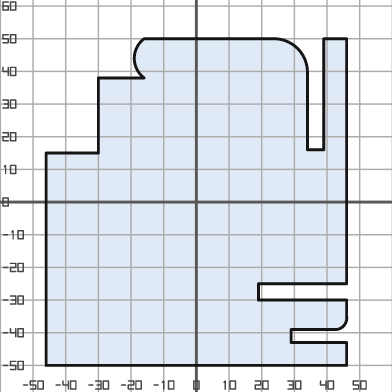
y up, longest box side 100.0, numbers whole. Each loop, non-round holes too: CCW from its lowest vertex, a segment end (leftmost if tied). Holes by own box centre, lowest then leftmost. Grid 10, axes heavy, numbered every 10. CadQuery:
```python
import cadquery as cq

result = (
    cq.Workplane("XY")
    .moveTo(-46.0, -50.0)
    .lineTo(46.0, -50.0)
    .lineTo(46.0, -43.0)
    .lineTo(29.0, -43.0)
    .lineTo(29.0, -39.0)
    .lineTo(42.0, -39.0)
    .threePointArc((45.0, -38.0), (46.0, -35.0))
    .lineTo(46.0, -30.0)
    .lineTo(19.0, -30.0)
    .lineTo(19.0, -25.0)
    .lineTo(46.0, -25.0)
    .lineTo(46.0, 50.0)
    .lineTo(39.0, 50.0)
    .lineTo(39.0, 16.0)
    .lineTo(34.0, 16.0)
    .lineTo(34.0, 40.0)
    .threePointArc((31.0, 47.0), (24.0, 50.0))
    .lineTo(-16.0, 50.0)
    .threePointArc((-19.0, 44.0), (-16.0, 38.0))
    .lineTo(-30.0, 38.0)
    .lineTo(-30.0, 15.0)
    .lineTo(-46.0, 15.0)
    .close()
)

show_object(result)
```